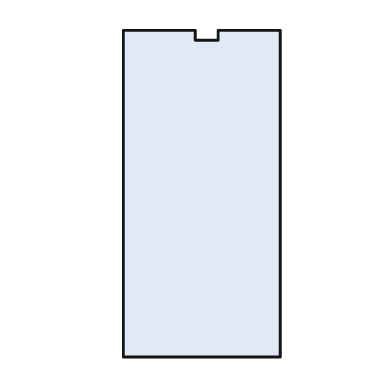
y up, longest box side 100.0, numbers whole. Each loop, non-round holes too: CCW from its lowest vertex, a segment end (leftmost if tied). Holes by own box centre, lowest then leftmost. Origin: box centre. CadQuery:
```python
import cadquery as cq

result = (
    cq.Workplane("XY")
    .moveTo(-24.0, -50.0)
    .lineTo(24.0, -50.0)
    .lineTo(24.0, 50.0)
    .lineTo(5.0, 50.0)
    .lineTo(5.0, 47.0)
    .lineTo(-2.0, 47.0)
    .lineTo(-2.0, 50.0)
    .lineTo(-24.0, 50.0)
    .close()
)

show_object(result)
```